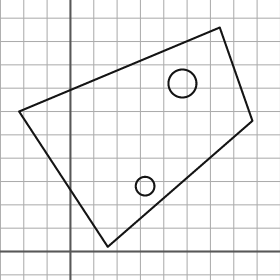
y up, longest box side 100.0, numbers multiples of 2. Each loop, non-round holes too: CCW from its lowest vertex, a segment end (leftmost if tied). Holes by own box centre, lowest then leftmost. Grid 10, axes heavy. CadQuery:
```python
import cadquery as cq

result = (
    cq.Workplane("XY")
    .moveTo(16.0, 2.0)
    .lineTo(78.0, 56.0)
    .lineTo(64.0, 96.0)
    .lineTo(-22.0, 60.0)
    .close()
    .moveTo(32.0, 28.0)
    .circle(4.0)
    .moveTo(48.0, 72.0)
    .circle(6.0)
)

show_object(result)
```